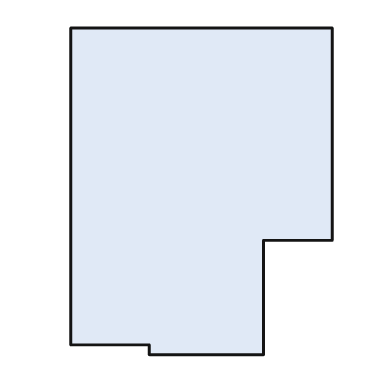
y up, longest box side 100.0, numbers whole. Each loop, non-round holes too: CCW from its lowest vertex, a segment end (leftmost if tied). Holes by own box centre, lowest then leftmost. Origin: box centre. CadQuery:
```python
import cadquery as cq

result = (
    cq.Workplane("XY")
    .moveTo(-16.0, -50.0)
    .lineTo(19.0, -50.0)
    .lineTo(19.0, -15.0)
    .lineTo(40.0, -15.0)
    .lineTo(40.0, 50.0)
    .lineTo(-40.0, 50.0)
    .lineTo(-40.0, -47.0)
    .lineTo(-16.0, -47.0)
    .close()
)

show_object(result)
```